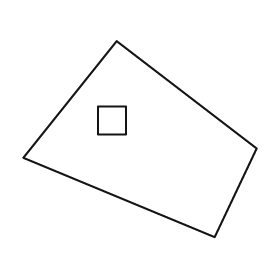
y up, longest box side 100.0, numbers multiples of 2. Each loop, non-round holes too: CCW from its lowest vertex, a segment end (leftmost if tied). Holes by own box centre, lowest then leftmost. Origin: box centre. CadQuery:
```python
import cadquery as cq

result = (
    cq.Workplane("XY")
    .moveTo(32.0, -42.0)
    .lineTo(50.0, -4.0)
    .lineTo(-10.0, 42.0)
    .lineTo(-50.0, -8.0)
    .close()
    .moveTo(-18.0, 2.0)
    .lineTo(-6.0, 2.0)
    .lineTo(-6.0, 14.0)
    .lineTo(-18.0, 14.0)
    .close()
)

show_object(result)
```